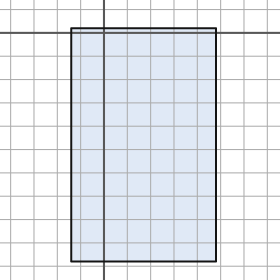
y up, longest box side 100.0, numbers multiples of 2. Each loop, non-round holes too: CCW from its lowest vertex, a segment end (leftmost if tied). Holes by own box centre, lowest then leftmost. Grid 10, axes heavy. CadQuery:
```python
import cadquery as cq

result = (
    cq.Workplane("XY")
    .moveTo(-14.0, -98.0)
    .lineTo(48.0, -98.0)
    .lineTo(48.0, 2.0)
    .lineTo(-14.0, 2.0)
    .close()
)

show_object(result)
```